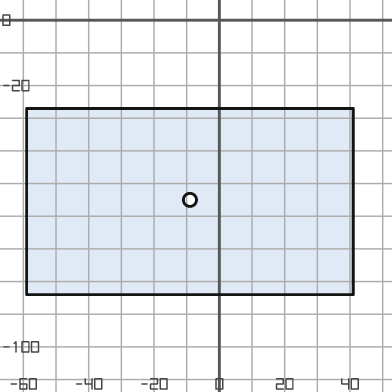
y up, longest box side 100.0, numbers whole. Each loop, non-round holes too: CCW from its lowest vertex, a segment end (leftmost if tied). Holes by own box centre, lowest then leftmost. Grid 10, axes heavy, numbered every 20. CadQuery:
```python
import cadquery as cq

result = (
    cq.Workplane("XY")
    .moveTo(-59.0, -84.0)
    .lineTo(41.0, -84.0)
    .lineTo(41.0, -27.0)
    .lineTo(-59.0, -27.0)
    .close()
    .moveTo(-9.0, -55.0)
    .circle(2.0)
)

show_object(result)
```